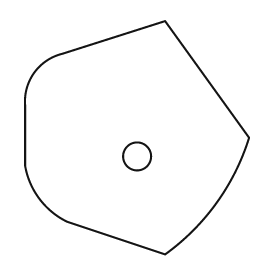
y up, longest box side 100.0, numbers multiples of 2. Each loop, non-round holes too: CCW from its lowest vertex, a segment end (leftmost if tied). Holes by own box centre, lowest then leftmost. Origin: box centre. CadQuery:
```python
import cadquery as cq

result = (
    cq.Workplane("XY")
    .moveTo(12.0, -50.0)
    .threePointArc((34.0, -28.0), (48.0, 0.0))
    .lineTo(12.0, 50.0)
    .lineTo(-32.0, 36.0)
    .threePointArc((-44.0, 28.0), (-48.0, 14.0))
    .lineTo(-48.0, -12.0)
    .threePointArc((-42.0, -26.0), (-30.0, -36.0))
    .close()
    .moveTo(0.0, -8.0)
    .circle(6.0)
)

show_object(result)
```